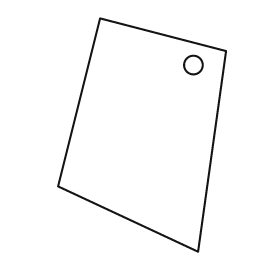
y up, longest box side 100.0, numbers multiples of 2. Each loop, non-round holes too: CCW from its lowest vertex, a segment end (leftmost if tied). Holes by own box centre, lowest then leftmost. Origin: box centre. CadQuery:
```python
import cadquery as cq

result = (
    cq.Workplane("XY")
    .moveTo(24.0, -50.0)
    .lineTo(36.0, 36.0)
    .lineTo(-18.0, 50.0)
    .lineTo(-36.0, -22.0)
    .close()
    .moveTo(22.0, 30.0)
    .circle(4.0)
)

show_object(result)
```